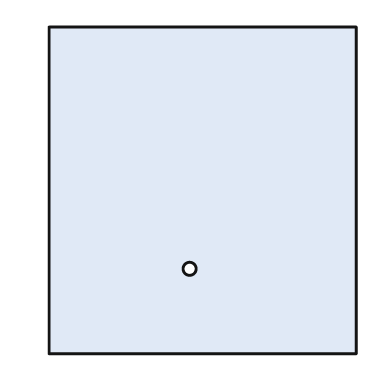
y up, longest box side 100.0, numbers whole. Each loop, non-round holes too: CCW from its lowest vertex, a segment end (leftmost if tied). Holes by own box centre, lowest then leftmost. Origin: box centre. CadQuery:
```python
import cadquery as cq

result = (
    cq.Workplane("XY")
    .moveTo(-47.0, -50.0)
    .lineTo(47.0, -50.0)
    .lineTo(47.0, 50.0)
    .lineTo(-47.0, 50.0)
    .close()
    .moveTo(-4.0, -24.0)
    .circle(2.0)
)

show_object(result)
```